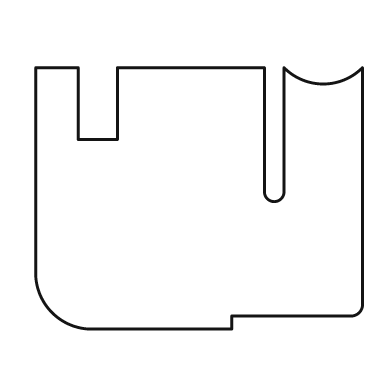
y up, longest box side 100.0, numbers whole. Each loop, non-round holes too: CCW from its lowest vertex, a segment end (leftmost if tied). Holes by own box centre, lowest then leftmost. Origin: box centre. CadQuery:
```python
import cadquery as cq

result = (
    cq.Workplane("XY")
    .moveTo(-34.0, -40.0)
    .lineTo(10.0, -40.0)
    .lineTo(10.0, -36.0)
    .lineTo(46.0, -36.0)
    .threePointArc((49.0, -35.0), (50.0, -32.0))
    .lineTo(50.0, 40.0)
    .threePointArc((38.0, 35.0), (26.0, 40.0))
    .lineTo(26.0, 2.0)
    .threePointArc((23.0, -1.0), (20.0, 2.0))
    .lineTo(20.0, 40.0)
    .lineTo(-25.0, 40.0)
    .lineTo(-25.0, 18.0)
    .lineTo(-37.0, 18.0)
    .lineTo(-37.0, 40.0)
    .lineTo(-50.0, 40.0)
    .lineTo(-50.0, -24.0)
    .threePointArc((-45.0, -35.0), (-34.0, -40.0))
    .close()
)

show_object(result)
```